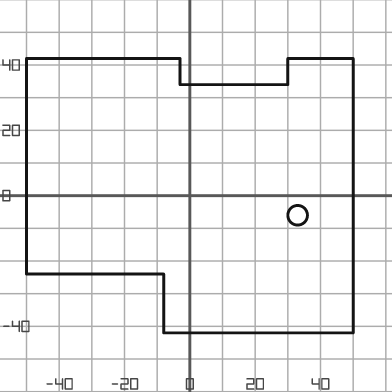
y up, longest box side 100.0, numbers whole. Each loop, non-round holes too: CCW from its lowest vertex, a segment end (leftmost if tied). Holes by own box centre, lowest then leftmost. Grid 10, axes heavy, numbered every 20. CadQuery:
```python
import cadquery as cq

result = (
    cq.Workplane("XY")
    .moveTo(-8.0, -42.0)
    .lineTo(50.0, -42.0)
    .lineTo(50.0, 42.0)
    .lineTo(30.0, 42.0)
    .lineTo(30.0, 34.0)
    .lineTo(-3.0, 34.0)
    .lineTo(-3.0, 42.0)
    .lineTo(-50.0, 42.0)
    .lineTo(-50.0, -24.0)
    .lineTo(-8.0, -24.0)
    .close()
    .moveTo(33.0, -6.0)
    .circle(3.0)
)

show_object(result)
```